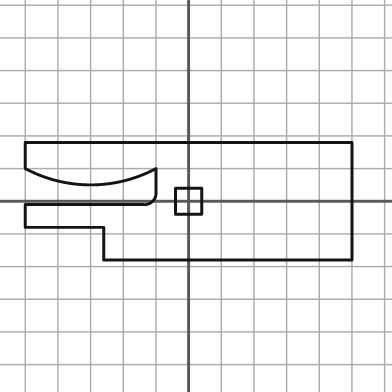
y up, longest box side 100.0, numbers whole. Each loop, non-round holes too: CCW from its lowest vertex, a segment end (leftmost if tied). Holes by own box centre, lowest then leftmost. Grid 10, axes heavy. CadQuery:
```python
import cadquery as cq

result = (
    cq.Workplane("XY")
    .moveTo(-26.0, -18.0)
    .lineTo(50.0, -18.0)
    .lineTo(50.0, 18.0)
    .lineTo(-50.0, 18.0)
    .lineTo(-50.0, 10.0)
    .threePointArc((-30.0, 5.0), (-10.0, 10.0))
    .lineTo(-10.0, 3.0)
    .threePointArc((-11.0, 0.0), (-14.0, -1.0))
    .lineTo(-50.0, -1.0)
    .lineTo(-50.0, -8.0)
    .lineTo(-26.0, -8.0)
    .close()
    .moveTo(-4.0, -4.0)
    .lineTo(4.0, -4.0)
    .lineTo(4.0, 4.0)
    .lineTo(-4.0, 4.0)
    .close()
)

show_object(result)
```